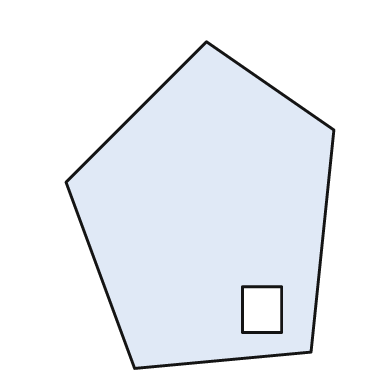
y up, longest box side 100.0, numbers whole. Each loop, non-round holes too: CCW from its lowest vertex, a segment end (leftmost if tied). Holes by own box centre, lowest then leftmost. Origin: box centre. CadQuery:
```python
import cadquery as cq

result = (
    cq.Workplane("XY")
    .moveTo(-20.0, -50.0)
    .lineTo(34.0, -45.0)
    .lineTo(41.0, 23.0)
    .lineTo(2.0, 50.0)
    .lineTo(-41.0, 7.0)
    .close()
    .moveTo(13.0, -39.0)
    .lineTo(25.0, -39.0)
    .lineTo(25.0, -25.0)
    .lineTo(13.0, -25.0)
    .close()
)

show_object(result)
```